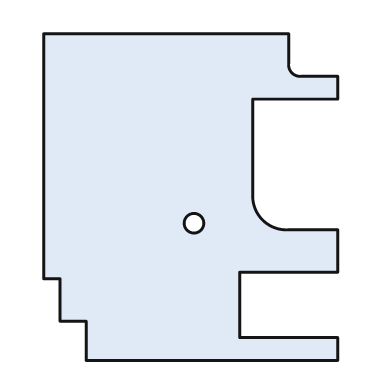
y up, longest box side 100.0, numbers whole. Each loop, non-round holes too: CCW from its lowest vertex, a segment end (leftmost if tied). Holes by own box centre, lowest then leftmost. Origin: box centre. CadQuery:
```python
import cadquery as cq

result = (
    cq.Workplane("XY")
    .moveTo(-32.0, -50.0)
    .lineTo(45.0, -50.0)
    .lineTo(45.0, -43.0)
    .lineTo(15.0, -43.0)
    .lineTo(15.0, -23.0)
    .lineTo(45.0, -23.0)
    .lineTo(45.0, -10.0)
    .lineTo(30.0, -10.0)
    .threePointArc((22.0, -7.0), (19.0, 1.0))
    .lineTo(19.0, 30.0)
    .lineTo(45.0, 30.0)
    .lineTo(45.0, 37.0)
    .lineTo(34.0, 37.0)
    .threePointArc((31.0, 38.0), (30.0, 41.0))
    .lineTo(30.0, 50.0)
    .lineTo(-45.0, 50.0)
    .lineTo(-45.0, -25.0)
    .lineTo(-40.0, -25.0)
    .lineTo(-40.0, -38.0)
    .lineTo(-32.0, -38.0)
    .close()
    .moveTo(1.0, -8.0)
    .circle(3.0)
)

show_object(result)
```